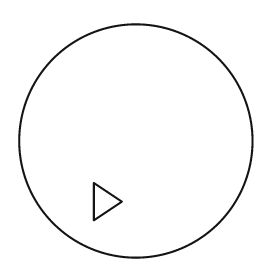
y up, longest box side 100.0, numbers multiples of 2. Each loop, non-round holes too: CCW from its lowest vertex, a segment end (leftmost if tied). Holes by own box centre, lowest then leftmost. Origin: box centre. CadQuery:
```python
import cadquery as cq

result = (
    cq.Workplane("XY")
    .moveTo(0.0, 0.0)
    .circle(50.0)
    .moveTo(-18.0, -34.0)
    .lineTo(-6.0, -26.0)
    .lineTo(-18.0, -18.0)
    .close()
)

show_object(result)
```